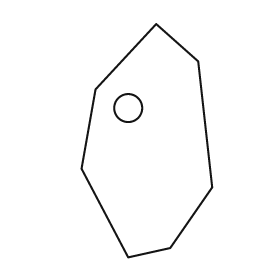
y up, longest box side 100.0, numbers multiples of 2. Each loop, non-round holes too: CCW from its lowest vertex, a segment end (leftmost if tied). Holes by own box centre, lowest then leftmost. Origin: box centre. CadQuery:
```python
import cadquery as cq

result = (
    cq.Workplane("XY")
    .moveTo(-8.0, -50.0)
    .lineTo(10.0, -46.0)
    .lineTo(28.0, -20.0)
    .lineTo(22.0, 34.0)
    .lineTo(4.0, 50.0)
    .lineTo(-22.0, 22.0)
    .lineTo(-28.0, -12.0)
    .close()
    .moveTo(-8.0, 14.0)
    .circle(6.0)
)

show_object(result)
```